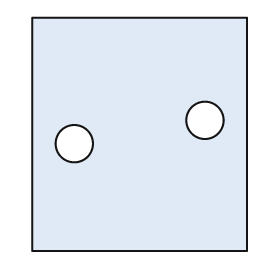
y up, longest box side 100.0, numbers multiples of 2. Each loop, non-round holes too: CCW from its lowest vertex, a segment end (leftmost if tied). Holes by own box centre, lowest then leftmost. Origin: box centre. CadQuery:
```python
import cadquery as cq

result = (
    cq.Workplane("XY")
    .moveTo(-46.0, -50.0)
    .lineTo(46.0, -50.0)
    .lineTo(46.0, 50.0)
    .lineTo(-46.0, 50.0)
    .close()
    .moveTo(-28.0, -4.0)
    .circle(8.0)
    .moveTo(28.0, 6.0)
    .circle(8.0)
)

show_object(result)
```